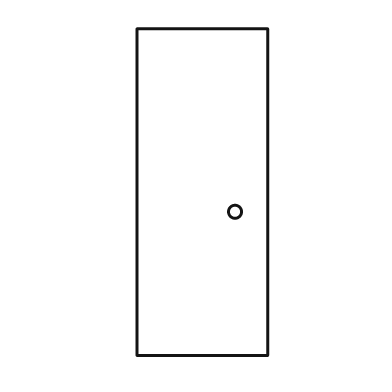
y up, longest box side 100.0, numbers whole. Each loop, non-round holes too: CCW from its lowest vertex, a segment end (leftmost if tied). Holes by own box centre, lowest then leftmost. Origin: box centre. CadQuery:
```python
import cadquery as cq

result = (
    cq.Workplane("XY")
    .moveTo(-20.0, -50.0)
    .lineTo(20.0, -50.0)
    .lineTo(20.0, 50.0)
    .lineTo(-20.0, 50.0)
    .close()
    .moveTo(10.0, -6.0)
    .circle(2.0)
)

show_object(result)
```